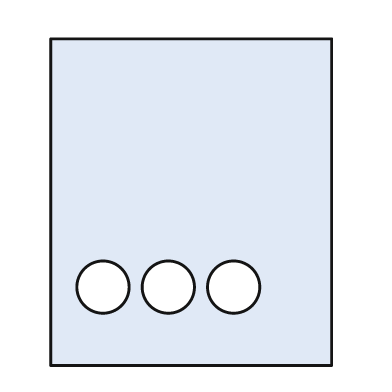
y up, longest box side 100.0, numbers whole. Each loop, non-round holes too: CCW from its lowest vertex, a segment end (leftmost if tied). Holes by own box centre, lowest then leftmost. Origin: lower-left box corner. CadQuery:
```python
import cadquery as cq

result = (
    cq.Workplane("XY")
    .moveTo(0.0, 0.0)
    .lineTo(86.0, 0.0)
    .lineTo(86.0, 100.0)
    .lineTo(0.0, 100.0)
    .close()
    .moveTo(16.0, 24.0)
    .circle(8.0)
    .moveTo(36.0, 24.0)
    .circle(8.0)
    .moveTo(56.0, 24.0)
    .circle(8.0)
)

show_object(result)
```